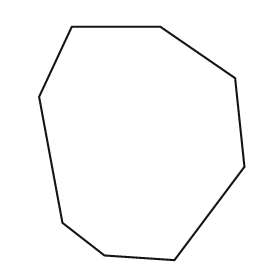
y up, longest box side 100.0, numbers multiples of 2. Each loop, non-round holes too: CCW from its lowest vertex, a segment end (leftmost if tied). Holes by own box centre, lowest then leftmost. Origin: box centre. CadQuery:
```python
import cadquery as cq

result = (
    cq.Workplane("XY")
    .moveTo(14.0, -50.0)
    .lineTo(44.0, -10.0)
    .lineTo(40.0, 28.0)
    .lineTo(8.0, 50.0)
    .lineTo(-30.0, 50.0)
    .lineTo(-44.0, 20.0)
    .lineTo(-34.0, -34.0)
    .lineTo(-16.0, -48.0)
    .close()
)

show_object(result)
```